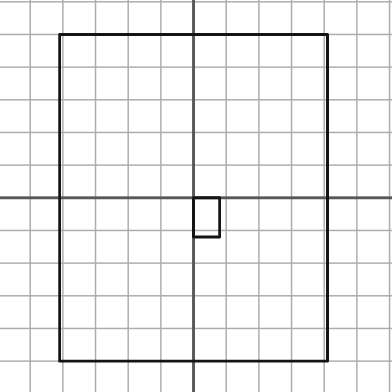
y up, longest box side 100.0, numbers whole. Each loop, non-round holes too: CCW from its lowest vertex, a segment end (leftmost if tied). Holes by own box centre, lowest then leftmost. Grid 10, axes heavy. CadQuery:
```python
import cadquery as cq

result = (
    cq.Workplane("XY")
    .moveTo(-41.0, -50.0)
    .lineTo(41.0, -50.0)
    .lineTo(41.0, 50.0)
    .lineTo(-41.0, 50.0)
    .close()
    .moveTo(0.0, -12.0)
    .lineTo(8.0, -12.0)
    .lineTo(8.0, 0.0)
    .lineTo(0.0, 0.0)
    .close()
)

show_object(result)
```